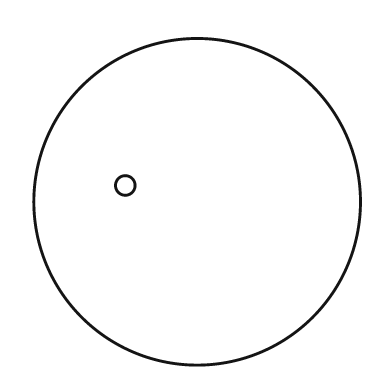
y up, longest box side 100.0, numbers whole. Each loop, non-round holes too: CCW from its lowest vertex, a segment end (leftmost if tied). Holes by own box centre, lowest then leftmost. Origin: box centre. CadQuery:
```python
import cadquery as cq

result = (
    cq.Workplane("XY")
    .moveTo(0.0, 0.0)
    .circle(50.0)
    .moveTo(-22.0, 5.0)
    .circle(3.0)
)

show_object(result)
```